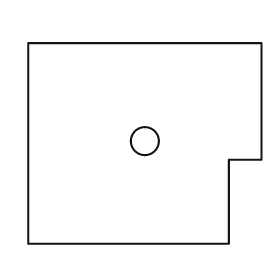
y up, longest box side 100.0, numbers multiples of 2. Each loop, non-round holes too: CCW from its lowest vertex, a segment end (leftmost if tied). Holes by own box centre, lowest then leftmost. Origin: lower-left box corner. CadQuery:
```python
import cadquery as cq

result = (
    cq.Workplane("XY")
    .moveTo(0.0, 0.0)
    .lineTo(86.0, 0.0)
    .lineTo(86.0, 36.0)
    .lineTo(100.0, 36.0)
    .lineTo(100.0, 86.0)
    .lineTo(0.0, 86.0)
    .close()
    .moveTo(50.0, 44.0)
    .circle(6.0)
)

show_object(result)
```